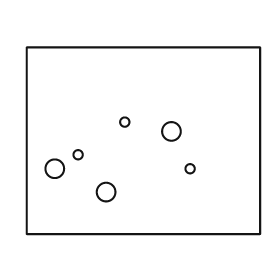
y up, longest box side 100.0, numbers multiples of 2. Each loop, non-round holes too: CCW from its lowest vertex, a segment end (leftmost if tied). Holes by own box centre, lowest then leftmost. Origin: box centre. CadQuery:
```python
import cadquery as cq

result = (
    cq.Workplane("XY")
    .moveTo(-50.0, -40.0)
    .lineTo(50.0, -40.0)
    .lineTo(50.0, 40.0)
    .lineTo(-50.0, 40.0)
    .close()
    .moveTo(-16.0, -22.0)
    .circle(4.0)
    .moveTo(-38.0, -12.0)
    .circle(4.0)
    .moveTo(20.0, -12.0)
    .circle(2.0)
    .moveTo(-28.0, -6.0)
    .circle(2.0)
    .moveTo(12.0, 4.0)
    .circle(4.0)
    .moveTo(-8.0, 8.0)
    .circle(2.0)
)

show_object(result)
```